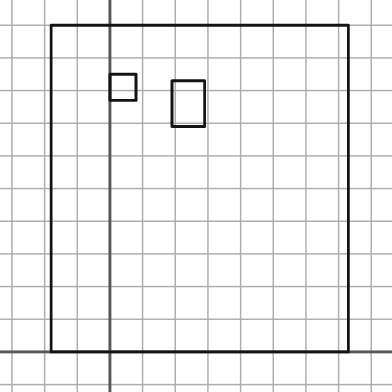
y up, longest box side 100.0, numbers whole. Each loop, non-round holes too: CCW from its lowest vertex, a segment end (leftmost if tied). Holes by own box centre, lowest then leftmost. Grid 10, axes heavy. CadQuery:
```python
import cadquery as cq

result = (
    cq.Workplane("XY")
    .moveTo(-18.0, 0.0)
    .lineTo(73.0, 0.0)
    .lineTo(73.0, 100.0)
    .lineTo(-18.0, 100.0)
    .close()
    .moveTo(19.0, 69.0)
    .lineTo(29.0, 69.0)
    .lineTo(29.0, 83.0)
    .lineTo(19.0, 83.0)
    .close()
    .moveTo(0.0, 77.0)
    .lineTo(8.0, 77.0)
    .lineTo(8.0, 85.0)
    .lineTo(0.0, 85.0)
    .close()
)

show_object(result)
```